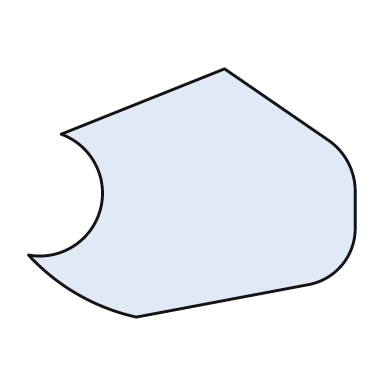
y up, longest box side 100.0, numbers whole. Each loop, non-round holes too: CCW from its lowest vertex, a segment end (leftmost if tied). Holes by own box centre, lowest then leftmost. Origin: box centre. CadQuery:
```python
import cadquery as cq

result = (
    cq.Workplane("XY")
    .moveTo(-17.0, -38.0)
    .lineTo(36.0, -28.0)
    .threePointArc((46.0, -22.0), (50.0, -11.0))
    .lineTo(50.0, 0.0)
    .threePointArc((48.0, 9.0), (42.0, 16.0))
    .lineTo(10.0, 38.0)
    .lineTo(-40.0, 18.0)
    .threePointArc((-28.0, -5.0), (-50.0, -19.0))
    .threePointArc((-35.0, -31.0), (-17.0, -38.0))
    .close()
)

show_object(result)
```